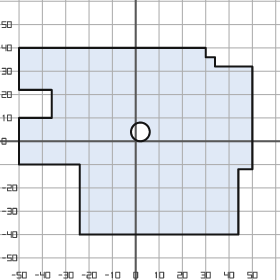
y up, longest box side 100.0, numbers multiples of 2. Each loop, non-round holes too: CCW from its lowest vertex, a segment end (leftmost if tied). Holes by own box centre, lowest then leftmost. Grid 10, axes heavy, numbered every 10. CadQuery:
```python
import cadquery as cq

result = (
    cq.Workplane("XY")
    .moveTo(-24.0, -40.0)
    .lineTo(44.0, -40.0)
    .lineTo(44.0, -12.0)
    .lineTo(50.0, -12.0)
    .lineTo(50.0, 32.0)
    .lineTo(34.0, 32.0)
    .lineTo(34.0, 36.0)
    .lineTo(30.0, 36.0)
    .lineTo(30.0, 40.0)
    .lineTo(-50.0, 40.0)
    .lineTo(-50.0, 22.0)
    .lineTo(-36.0, 22.0)
    .lineTo(-36.0, 10.0)
    .lineTo(-50.0, 10.0)
    .lineTo(-50.0, -10.0)
    .lineTo(-24.0, -10.0)
    .close()
    .moveTo(2.0, 4.0)
    .circle(4.0)
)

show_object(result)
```